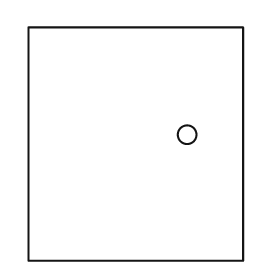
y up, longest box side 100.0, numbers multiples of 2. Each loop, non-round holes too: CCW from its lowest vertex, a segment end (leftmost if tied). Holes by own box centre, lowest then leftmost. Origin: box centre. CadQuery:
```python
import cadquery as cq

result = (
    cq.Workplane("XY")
    .moveTo(-46.0, -50.0)
    .lineTo(46.0, -50.0)
    .lineTo(46.0, 50.0)
    .lineTo(-46.0, 50.0)
    .close()
    .moveTo(22.0, 4.0)
    .circle(4.0)
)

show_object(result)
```